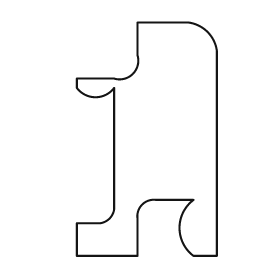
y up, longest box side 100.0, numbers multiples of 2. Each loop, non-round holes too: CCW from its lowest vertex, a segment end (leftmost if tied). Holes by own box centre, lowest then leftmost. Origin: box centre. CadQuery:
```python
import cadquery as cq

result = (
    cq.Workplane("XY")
    .moveTo(-30.0, -50.0)
    .lineTo(-4.0, -50.0)
    .lineTo(-4.0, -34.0)
    .threePointArc((-2.0, -28.0), (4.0, -26.0))
    .lineTo(20.0, -26.0)
    .threePointArc((14.0, -38.0), (20.0, -50.0))
    .lineTo(30.0, -50.0)
    .lineTo(30.0, 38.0)
    .threePointArc((26.0, 46.0), (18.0, 50.0))
    .lineTo(-4.0, 50.0)
    .lineTo(-4.0, 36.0)
    .threePointArc((-6.0, 28.0), (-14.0, 26.0))
    .lineTo(-30.0, 26.0)
    .lineTo(-30.0, 22.0)
    .threePointArc((-22.0, 18.0), (-14.0, 22.0))
    .lineTo(-14.0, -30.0)
    .threePointArc((-16.0, -34.0), (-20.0, -36.0))
    .lineTo(-30.0, -36.0)
    .close()
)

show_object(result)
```